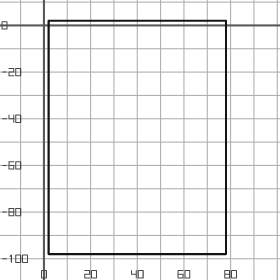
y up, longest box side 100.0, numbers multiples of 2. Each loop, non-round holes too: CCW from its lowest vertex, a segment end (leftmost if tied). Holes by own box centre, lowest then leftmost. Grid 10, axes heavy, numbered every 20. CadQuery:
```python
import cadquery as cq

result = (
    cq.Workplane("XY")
    .moveTo(2.0, -98.0)
    .lineTo(78.0, -98.0)
    .lineTo(78.0, 2.0)
    .lineTo(2.0, 2.0)
    .close()
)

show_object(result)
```